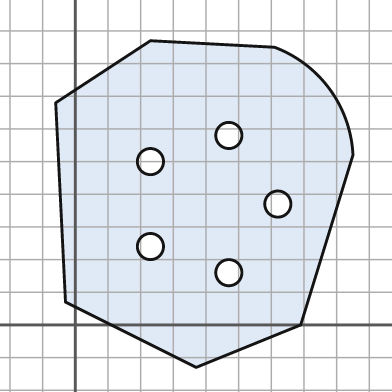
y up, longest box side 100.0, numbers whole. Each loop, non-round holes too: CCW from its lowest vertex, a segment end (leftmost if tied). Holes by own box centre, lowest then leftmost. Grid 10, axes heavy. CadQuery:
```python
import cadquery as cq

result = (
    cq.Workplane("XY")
    .moveTo(37.0, -13.0)
    .lineTo(69.0, 0.0)
    .lineTo(85.0, 52.0)
    .threePointArc((78.0, 72.0), (61.0, 85.0))
    .lineTo(23.0, 87.0)
    .lineTo(-6.0, 68.0)
    .lineTo(-3.0, 7.0)
    .close()
    .moveTo(47.0, 16.0)
    .circle(4.0)
    .moveTo(23.0, 24.0)
    .circle(4.0)
    .moveTo(62.0, 37.0)
    .circle(4.0)
    .moveTo(23.0, 50.0)
    .circle(4.0)
    .moveTo(47.0, 58.0)
    .circle(4.0)
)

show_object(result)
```